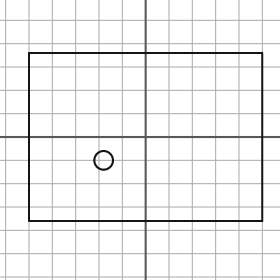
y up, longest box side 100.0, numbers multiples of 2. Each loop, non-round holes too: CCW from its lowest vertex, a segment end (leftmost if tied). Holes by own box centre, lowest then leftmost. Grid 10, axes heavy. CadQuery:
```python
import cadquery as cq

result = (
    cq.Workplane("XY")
    .moveTo(-50.0, -36.0)
    .lineTo(50.0, -36.0)
    .lineTo(50.0, 36.0)
    .lineTo(-50.0, 36.0)
    .close()
    .moveTo(-18.0, -10.0)
    .circle(4.0)
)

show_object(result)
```